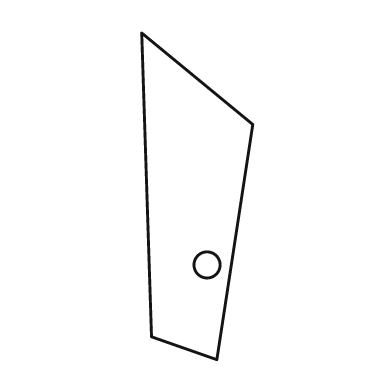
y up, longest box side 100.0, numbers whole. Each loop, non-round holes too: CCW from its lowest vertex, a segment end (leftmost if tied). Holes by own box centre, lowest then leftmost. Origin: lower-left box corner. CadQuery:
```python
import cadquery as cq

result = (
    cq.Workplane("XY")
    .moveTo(23.0, 0.0)
    .lineTo(34.0, 72.0)
    .lineTo(0.0, 100.0)
    .lineTo(3.0, 7.0)
    .close()
    .moveTo(20.0, 29.0)
    .circle(4.0)
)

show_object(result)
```